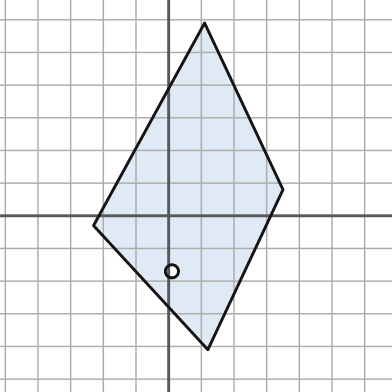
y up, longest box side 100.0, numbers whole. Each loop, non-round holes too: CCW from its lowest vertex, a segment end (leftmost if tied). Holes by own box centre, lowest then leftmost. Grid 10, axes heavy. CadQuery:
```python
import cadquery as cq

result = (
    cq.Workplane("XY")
    .moveTo(12.0, -41.0)
    .lineTo(35.0, 8.0)
    .lineTo(11.0, 59.0)
    .lineTo(-23.0, -3.0)
    .close()
    .moveTo(1.0, -17.0)
    .circle(2.0)
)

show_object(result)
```